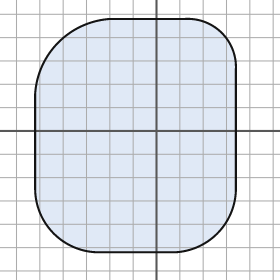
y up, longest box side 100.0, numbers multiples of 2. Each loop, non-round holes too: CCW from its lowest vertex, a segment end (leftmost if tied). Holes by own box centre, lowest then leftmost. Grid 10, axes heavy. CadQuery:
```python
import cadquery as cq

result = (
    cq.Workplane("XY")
    .moveTo(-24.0, -52.0)
    .lineTo(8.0, -52.0)
    .threePointArc((26.0, -44.0), (34.0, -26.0))
    .lineTo(34.0, 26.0)
    .threePointArc((28.0, 42.0), (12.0, 48.0))
    .lineTo(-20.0, 48.0)
    .threePointArc((-42.0, 38.0), (-52.0, 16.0))
    .lineTo(-52.0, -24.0)
    .threePointArc((-44.0, -44.0), (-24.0, -52.0))
    .close()
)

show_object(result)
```